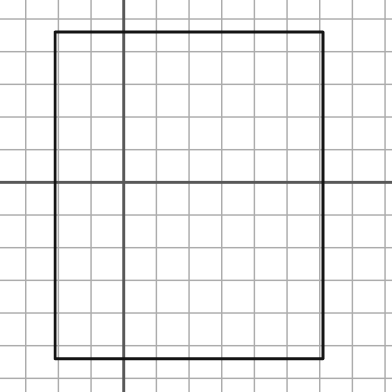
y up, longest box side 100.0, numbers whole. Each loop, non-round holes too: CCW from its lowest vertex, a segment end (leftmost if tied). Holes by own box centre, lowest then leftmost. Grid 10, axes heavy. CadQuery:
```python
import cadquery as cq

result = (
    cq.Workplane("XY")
    .moveTo(-21.0, -54.0)
    .lineTo(61.0, -54.0)
    .lineTo(61.0, 46.0)
    .lineTo(-21.0, 46.0)
    .close()
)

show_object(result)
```